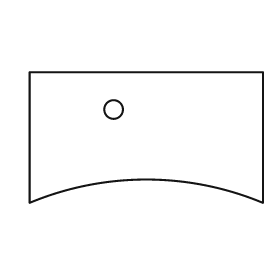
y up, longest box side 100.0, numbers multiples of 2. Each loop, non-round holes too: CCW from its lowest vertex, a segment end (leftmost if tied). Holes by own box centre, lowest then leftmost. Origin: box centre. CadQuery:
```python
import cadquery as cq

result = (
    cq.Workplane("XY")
    .moveTo(-50.0, -28.0)
    .threePointArc((0.0, -18.0), (50.0, -28.0))
    .lineTo(50.0, 28.0)
    .lineTo(-50.0, 28.0)
    .close()
    .moveTo(-14.0, 12.0)
    .circle(4.0)
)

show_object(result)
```